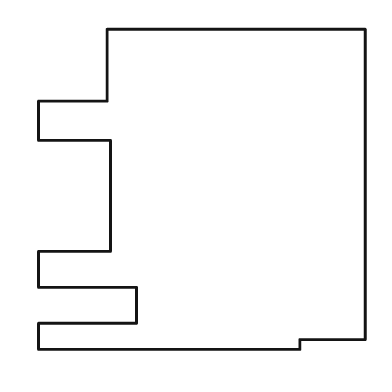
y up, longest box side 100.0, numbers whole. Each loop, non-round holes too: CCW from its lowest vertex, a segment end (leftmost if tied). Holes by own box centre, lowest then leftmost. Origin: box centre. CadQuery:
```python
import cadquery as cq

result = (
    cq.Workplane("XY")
    .moveTo(-50.0, -49.0)
    .lineTo(30.0, -49.0)
    .lineTo(30.0, -46.0)
    .lineTo(50.0, -46.0)
    .lineTo(50.0, 49.0)
    .lineTo(-29.0, 49.0)
    .lineTo(-29.0, 27.0)
    .lineTo(-50.0, 27.0)
    .lineTo(-50.0, 15.0)
    .lineTo(-28.0, 15.0)
    .lineTo(-28.0, -19.0)
    .lineTo(-50.0, -19.0)
    .lineTo(-50.0, -30.0)
    .lineTo(-20.0, -30.0)
    .lineTo(-20.0, -41.0)
    .lineTo(-50.0, -41.0)
    .close()
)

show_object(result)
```